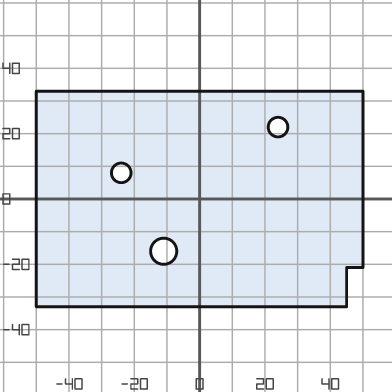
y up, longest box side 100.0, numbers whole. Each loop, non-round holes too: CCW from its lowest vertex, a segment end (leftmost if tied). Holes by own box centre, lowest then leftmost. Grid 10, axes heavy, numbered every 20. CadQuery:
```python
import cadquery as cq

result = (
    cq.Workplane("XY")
    .moveTo(-50.0, -33.0)
    .lineTo(45.0, -33.0)
    .lineTo(45.0, -21.0)
    .lineTo(50.0, -21.0)
    .lineTo(50.0, 33.0)
    .lineTo(-50.0, 33.0)
    .close()
    .moveTo(-11.0, -16.0)
    .circle(4.0)
    .moveTo(-24.0, 8.0)
    .circle(3.0)
    .moveTo(24.0, 22.0)
    .circle(3.0)
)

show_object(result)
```